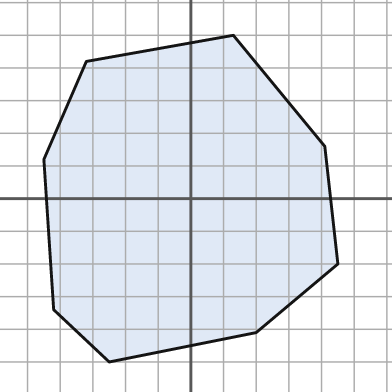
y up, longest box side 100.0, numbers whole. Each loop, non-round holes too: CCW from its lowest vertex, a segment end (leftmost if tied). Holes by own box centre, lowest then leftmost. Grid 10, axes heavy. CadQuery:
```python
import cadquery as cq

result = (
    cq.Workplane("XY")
    .moveTo(-25.0, -50.0)
    .lineTo(20.0, -41.0)
    .lineTo(45.0, -20.0)
    .lineTo(41.0, 16.0)
    .lineTo(13.0, 50.0)
    .lineTo(-32.0, 42.0)
    .lineTo(-45.0, 12.0)
    .lineTo(-42.0, -34.0)
    .close()
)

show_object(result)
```